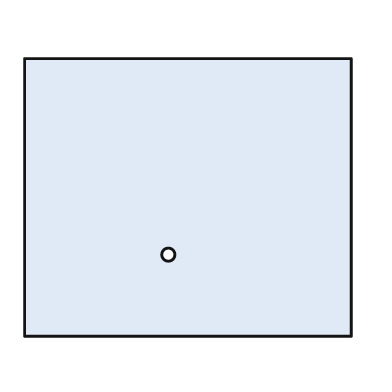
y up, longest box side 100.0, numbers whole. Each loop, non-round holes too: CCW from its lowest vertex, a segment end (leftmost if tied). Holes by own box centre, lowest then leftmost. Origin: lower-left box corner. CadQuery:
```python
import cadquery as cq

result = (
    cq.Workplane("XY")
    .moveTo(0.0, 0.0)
    .lineTo(100.0, 0.0)
    .lineTo(100.0, 85.0)
    .lineTo(0.0, 85.0)
    .close()
    .moveTo(44.0, 25.0)
    .circle(2.0)
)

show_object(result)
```